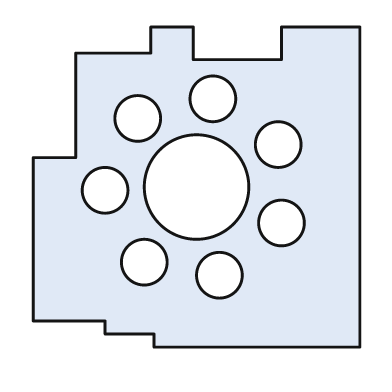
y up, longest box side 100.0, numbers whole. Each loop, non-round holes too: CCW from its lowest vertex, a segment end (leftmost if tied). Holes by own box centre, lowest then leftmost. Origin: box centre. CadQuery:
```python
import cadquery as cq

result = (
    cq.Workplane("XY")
    .moveTo(-13.0, -49.0)
    .lineTo(50.0, -49.0)
    .lineTo(50.0, 49.0)
    .lineTo(26.0, 49.0)
    .lineTo(26.0, 39.0)
    .lineTo(-1.0, 39.0)
    .lineTo(-1.0, 49.0)
    .lineTo(-14.0, 49.0)
    .lineTo(-14.0, 41.0)
    .lineTo(-37.0, 41.0)
    .lineTo(-37.0, 9.0)
    .lineTo(-50.0, 9.0)
    .lineTo(-50.0, -41.0)
    .lineTo(-28.0, -41.0)
    .lineTo(-28.0, -45.0)
    .lineTo(-13.0, -45.0)
    .close()
    .moveTo(7.0, -27.0)
    .circle(7.0)
    .moveTo(-16.0, -23.0)
    .circle(7.0)
    .moveTo(26.0, -11.0)
    .circle(7.0)
    .moveTo(-28.0, -1.0)
    .circle(7.0)
    .moveTo(0.0, 0.0)
    .circle(16.0)
    .moveTo(25.0, 13.0)
    .circle(7.0)
    .moveTo(-18.0, 21.0)
    .circle(7.0)
    .moveTo(5.0, 27.0)
    .circle(7.0)
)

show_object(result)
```